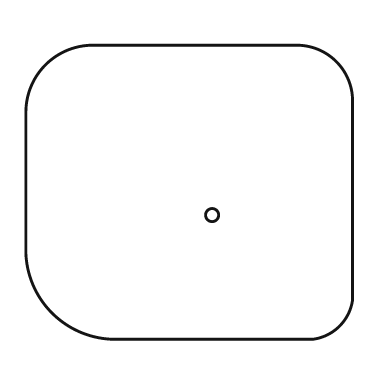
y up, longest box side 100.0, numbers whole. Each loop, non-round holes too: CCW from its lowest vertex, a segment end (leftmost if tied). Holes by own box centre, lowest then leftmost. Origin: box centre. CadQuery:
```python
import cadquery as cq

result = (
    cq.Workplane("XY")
    .moveTo(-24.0, -45.0)
    .lineTo(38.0, -45.0)
    .threePointArc((46.0, -41.0), (50.0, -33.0))
    .lineTo(50.0, 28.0)
    .threePointArc((45.0, 40.0), (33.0, 45.0))
    .lineTo(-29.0, 45.0)
    .threePointArc((-44.0, 39.0), (-50.0, 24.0))
    .lineTo(-50.0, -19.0)
    .threePointArc((-42.0, -37.0), (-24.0, -45.0))
    .close()
    .moveTo(7.0, -7.0)
    .circle(2.0)
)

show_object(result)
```